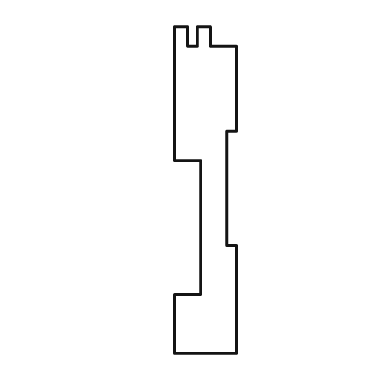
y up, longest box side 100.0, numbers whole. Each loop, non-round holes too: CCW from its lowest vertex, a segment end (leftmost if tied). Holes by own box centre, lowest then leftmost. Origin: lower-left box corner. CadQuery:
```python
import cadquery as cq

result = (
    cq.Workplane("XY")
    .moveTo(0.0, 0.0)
    .lineTo(19.0, 0.0)
    .lineTo(19.0, 33.0)
    .lineTo(16.0, 33.0)
    .lineTo(16.0, 68.0)
    .lineTo(19.0, 68.0)
    .lineTo(19.0, 94.0)
    .lineTo(11.0, 94.0)
    .lineTo(11.0, 100.0)
    .lineTo(7.0, 100.0)
    .lineTo(7.0, 94.0)
    .lineTo(4.0, 94.0)
    .lineTo(4.0, 100.0)
    .lineTo(0.0, 100.0)
    .lineTo(0.0, 59.0)
    .lineTo(8.0, 59.0)
    .lineTo(8.0, 18.0)
    .lineTo(0.0, 18.0)
    .close()
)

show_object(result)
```